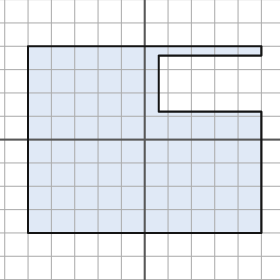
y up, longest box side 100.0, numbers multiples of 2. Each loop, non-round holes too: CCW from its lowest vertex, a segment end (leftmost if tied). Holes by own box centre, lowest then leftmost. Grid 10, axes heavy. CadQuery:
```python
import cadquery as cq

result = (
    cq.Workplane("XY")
    .moveTo(-50.0, -40.0)
    .lineTo(50.0, -40.0)
    .lineTo(50.0, 12.0)
    .lineTo(6.0, 12.0)
    .lineTo(6.0, 36.0)
    .lineTo(50.0, 36.0)
    .lineTo(50.0, 40.0)
    .lineTo(-50.0, 40.0)
    .close()
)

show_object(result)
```